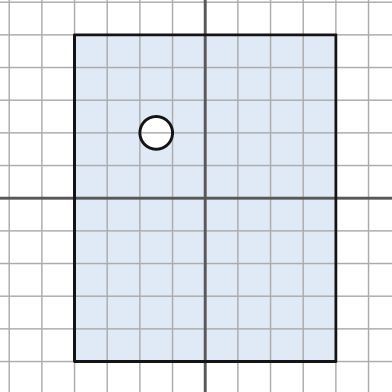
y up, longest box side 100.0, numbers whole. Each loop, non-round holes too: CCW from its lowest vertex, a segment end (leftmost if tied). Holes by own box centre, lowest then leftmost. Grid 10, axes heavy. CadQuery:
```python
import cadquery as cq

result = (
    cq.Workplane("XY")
    .moveTo(-40.0, -50.0)
    .lineTo(40.0, -50.0)
    .lineTo(40.0, 50.0)
    .lineTo(-40.0, 50.0)
    .close()
    .moveTo(-15.0, 20.0)
    .circle(5.0)
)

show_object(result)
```